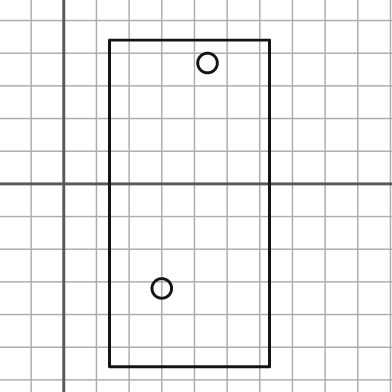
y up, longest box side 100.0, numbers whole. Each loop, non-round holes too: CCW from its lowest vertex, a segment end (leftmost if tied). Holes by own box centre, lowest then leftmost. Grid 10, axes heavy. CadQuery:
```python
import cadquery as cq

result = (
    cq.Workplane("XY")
    .moveTo(14.0, -56.0)
    .lineTo(63.0, -56.0)
    .lineTo(63.0, 44.0)
    .lineTo(14.0, 44.0)
    .close()
    .moveTo(30.0, -32.0)
    .circle(3.0)
    .moveTo(44.0, 37.0)
    .circle(3.0)
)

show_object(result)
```